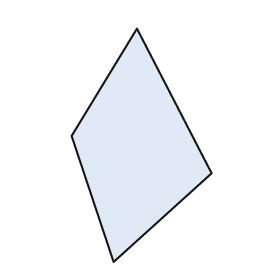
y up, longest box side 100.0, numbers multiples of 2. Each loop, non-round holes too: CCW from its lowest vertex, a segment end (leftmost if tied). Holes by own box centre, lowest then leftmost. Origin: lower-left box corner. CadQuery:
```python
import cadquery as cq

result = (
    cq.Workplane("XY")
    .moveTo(18.0, 0.0)
    .lineTo(60.0, 38.0)
    .lineTo(28.0, 100.0)
    .lineTo(0.0, 54.0)
    .close()
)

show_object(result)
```